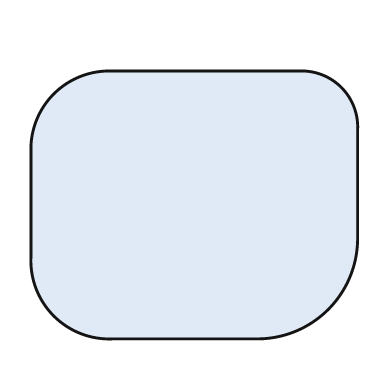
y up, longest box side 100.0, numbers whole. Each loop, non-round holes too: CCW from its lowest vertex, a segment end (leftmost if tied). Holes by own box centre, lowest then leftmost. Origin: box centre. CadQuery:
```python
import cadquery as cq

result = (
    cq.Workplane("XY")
    .moveTo(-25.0, -41.0)
    .lineTo(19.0, -41.0)
    .threePointArc((41.0, -32.0), (50.0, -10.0))
    .lineTo(50.0, 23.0)
    .threePointArc((45.0, 36.0), (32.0, 41.0))
    .lineTo(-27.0, 41.0)
    .threePointArc((-43.0, 34.0), (-50.0, 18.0))
    .lineTo(-50.0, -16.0)
    .threePointArc((-43.0, -34.0), (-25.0, -41.0))
    .close()
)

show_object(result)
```